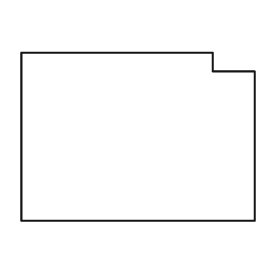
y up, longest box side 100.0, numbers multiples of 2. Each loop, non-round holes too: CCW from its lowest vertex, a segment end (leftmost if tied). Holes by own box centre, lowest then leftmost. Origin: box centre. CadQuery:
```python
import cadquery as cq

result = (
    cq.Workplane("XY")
    .moveTo(-50.0, -36.0)
    .lineTo(50.0, -36.0)
    .lineTo(50.0, 28.0)
    .lineTo(32.0, 28.0)
    .lineTo(32.0, 36.0)
    .lineTo(-50.0, 36.0)
    .close()
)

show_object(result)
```